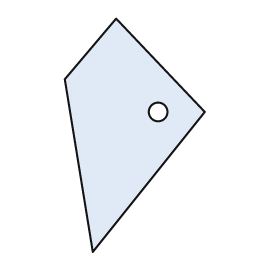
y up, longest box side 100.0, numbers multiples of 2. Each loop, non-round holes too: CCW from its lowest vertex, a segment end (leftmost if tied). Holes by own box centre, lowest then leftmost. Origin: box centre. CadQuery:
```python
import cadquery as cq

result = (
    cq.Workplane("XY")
    .moveTo(-18.0, -50.0)
    .lineTo(30.0, 10.0)
    .lineTo(-8.0, 50.0)
    .lineTo(-30.0, 24.0)
    .close()
    .moveTo(10.0, 10.0)
    .circle(4.0)
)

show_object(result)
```